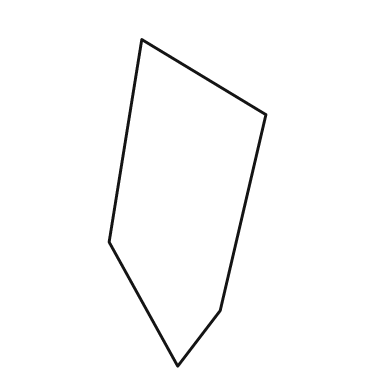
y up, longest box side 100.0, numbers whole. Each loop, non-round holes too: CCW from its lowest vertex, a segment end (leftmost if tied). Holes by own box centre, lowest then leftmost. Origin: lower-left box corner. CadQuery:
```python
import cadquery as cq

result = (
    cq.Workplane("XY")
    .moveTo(21.0, 0.0)
    .lineTo(34.0, 17.0)
    .lineTo(48.0, 77.0)
    .lineTo(10.0, 100.0)
    .lineTo(0.0, 38.0)
    .close()
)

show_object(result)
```